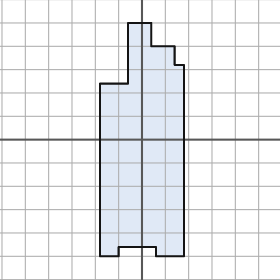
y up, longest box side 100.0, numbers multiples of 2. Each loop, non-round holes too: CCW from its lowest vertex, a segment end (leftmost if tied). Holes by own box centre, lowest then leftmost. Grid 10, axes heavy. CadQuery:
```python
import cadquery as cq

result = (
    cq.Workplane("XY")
    .moveTo(-18.0, -50.0)
    .lineTo(-10.0, -50.0)
    .lineTo(-10.0, -46.0)
    .lineTo(6.0, -46.0)
    .lineTo(6.0, -50.0)
    .lineTo(18.0, -50.0)
    .lineTo(18.0, 32.0)
    .lineTo(14.0, 32.0)
    .lineTo(14.0, 40.0)
    .lineTo(4.0, 40.0)
    .lineTo(4.0, 50.0)
    .lineTo(-6.0, 50.0)
    .lineTo(-6.0, 24.0)
    .lineTo(-18.0, 24.0)
    .close()
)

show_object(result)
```